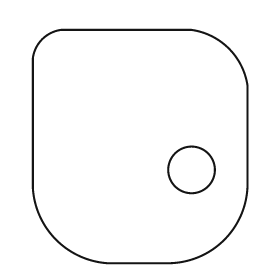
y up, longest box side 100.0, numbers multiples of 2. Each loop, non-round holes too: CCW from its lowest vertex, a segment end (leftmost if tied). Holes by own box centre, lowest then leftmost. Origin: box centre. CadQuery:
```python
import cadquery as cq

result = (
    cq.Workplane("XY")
    .moveTo(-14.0, -50.0)
    .lineTo(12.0, -50.0)
    .threePointArc((36.0, -40.0), (46.0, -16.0))
    .lineTo(46.0, 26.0)
    .threePointArc((38.0, 42.0), (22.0, 50.0))
    .lineTo(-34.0, 50.0)
    .threePointArc((-42.0, 46.0), (-46.0, 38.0))
    .lineTo(-46.0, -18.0)
    .threePointArc((-36.0, -40.0), (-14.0, -50.0))
    .close()
    .moveTo(22.0, -10.0)
    .circle(10.0)
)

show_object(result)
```